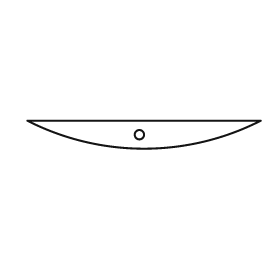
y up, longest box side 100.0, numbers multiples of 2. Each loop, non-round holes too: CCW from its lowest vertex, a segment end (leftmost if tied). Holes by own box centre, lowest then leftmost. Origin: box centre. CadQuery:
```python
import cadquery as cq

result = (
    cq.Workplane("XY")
    .moveTo(-50.0, 6.0)
    .threePointArc((0.0, -6.0), (50.0, 6.0))
    .close()
    .moveTo(-2.0, 0.0)
    .circle(2.0)
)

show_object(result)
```